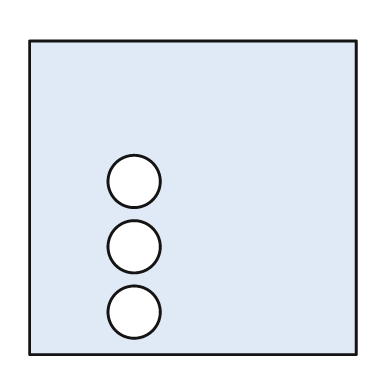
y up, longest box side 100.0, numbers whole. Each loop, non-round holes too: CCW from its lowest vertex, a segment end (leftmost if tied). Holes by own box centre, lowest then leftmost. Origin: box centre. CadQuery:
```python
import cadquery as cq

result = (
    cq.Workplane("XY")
    .moveTo(-50.0, -48.0)
    .lineTo(50.0, -48.0)
    .lineTo(50.0, 48.0)
    .lineTo(-50.0, 48.0)
    .close()
    .moveTo(-18.0, -35.0)
    .circle(8.0)
    .moveTo(-18.0, -15.0)
    .circle(8.0)
    .moveTo(-18.0, 5.0)
    .circle(8.0)
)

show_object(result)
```